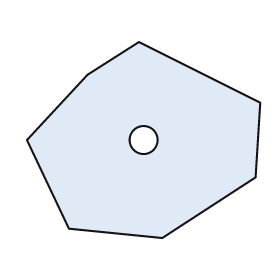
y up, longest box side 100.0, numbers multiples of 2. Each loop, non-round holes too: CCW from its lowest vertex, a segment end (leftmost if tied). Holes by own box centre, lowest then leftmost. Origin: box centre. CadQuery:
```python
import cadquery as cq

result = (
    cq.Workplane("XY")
    .moveTo(8.0, -42.0)
    .lineTo(48.0, -16.0)
    .lineTo(50.0, 16.0)
    .lineTo(-2.0, 42.0)
    .lineTo(-24.0, 28.0)
    .lineTo(-50.0, 0.0)
    .lineTo(-32.0, -38.0)
    .close()
    .moveTo(0.0, 0.0)
    .circle(6.0)
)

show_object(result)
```